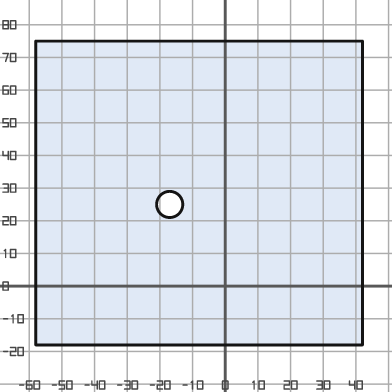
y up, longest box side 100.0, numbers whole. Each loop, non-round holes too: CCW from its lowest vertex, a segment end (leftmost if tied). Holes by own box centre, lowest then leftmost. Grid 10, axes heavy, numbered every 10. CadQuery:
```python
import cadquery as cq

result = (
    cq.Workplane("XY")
    .moveTo(-58.0, -18.0)
    .lineTo(42.0, -18.0)
    .lineTo(42.0, 75.0)
    .lineTo(-58.0, 75.0)
    .close()
    .moveTo(-17.0, 25.0)
    .circle(4.0)
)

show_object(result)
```